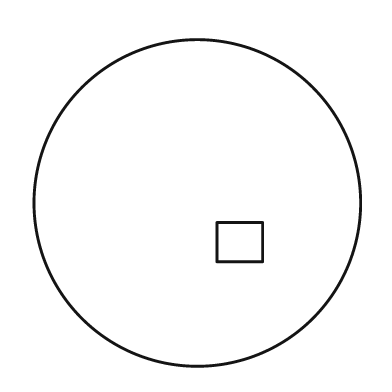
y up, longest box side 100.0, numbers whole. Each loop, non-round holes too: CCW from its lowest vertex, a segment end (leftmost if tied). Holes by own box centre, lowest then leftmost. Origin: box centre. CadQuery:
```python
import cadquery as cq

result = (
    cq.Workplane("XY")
    .moveTo(0.0, 0.0)
    .circle(50.0)
    .moveTo(6.0, -18.0)
    .lineTo(20.0, -18.0)
    .lineTo(20.0, -6.0)
    .lineTo(6.0, -6.0)
    .close()
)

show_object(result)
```